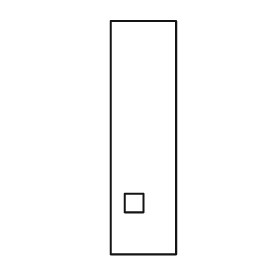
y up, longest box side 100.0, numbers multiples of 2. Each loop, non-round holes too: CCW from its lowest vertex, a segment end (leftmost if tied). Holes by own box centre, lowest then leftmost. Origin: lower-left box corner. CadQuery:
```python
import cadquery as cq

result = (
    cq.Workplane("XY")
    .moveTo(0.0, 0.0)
    .lineTo(28.0, 0.0)
    .lineTo(28.0, 100.0)
    .lineTo(0.0, 100.0)
    .close()
    .moveTo(6.0, 18.0)
    .lineTo(14.0, 18.0)
    .lineTo(14.0, 26.0)
    .lineTo(6.0, 26.0)
    .close()
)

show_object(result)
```